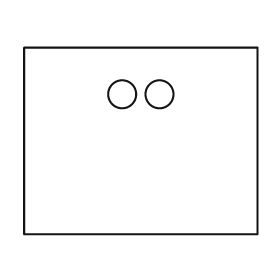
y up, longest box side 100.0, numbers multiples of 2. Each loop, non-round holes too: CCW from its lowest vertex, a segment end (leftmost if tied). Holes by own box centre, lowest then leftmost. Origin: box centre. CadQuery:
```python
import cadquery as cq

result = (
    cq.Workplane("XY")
    .moveTo(-50.0, -40.0)
    .lineTo(50.0, -40.0)
    .lineTo(50.0, 40.0)
    .lineTo(-50.0, 40.0)
    .close()
    .moveTo(-8.0, 20.0)
    .circle(6.0)
    .moveTo(8.0, 20.0)
    .circle(6.0)
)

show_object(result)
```